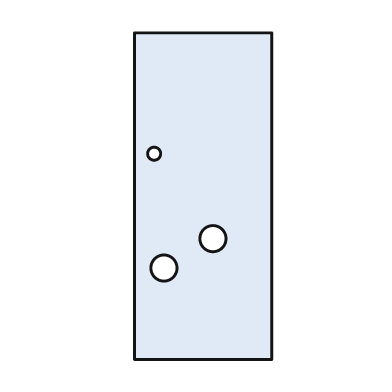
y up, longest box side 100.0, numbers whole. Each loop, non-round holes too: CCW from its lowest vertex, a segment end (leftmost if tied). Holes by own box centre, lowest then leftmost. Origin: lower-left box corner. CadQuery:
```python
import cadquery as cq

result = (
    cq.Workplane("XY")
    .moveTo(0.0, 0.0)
    .lineTo(42.0, 0.0)
    .lineTo(42.0, 100.0)
    .lineTo(0.0, 100.0)
    .close()
    .moveTo(9.0, 28.0)
    .circle(4.0)
    .moveTo(24.0, 37.0)
    .circle(4.0)
    .moveTo(6.0, 63.0)
    .circle(2.0)
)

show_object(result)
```